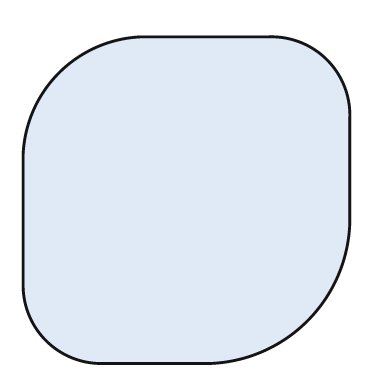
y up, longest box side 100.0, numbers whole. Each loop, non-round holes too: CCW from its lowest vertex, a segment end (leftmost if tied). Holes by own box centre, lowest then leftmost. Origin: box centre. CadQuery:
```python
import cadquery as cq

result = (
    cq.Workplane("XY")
    .moveTo(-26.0, -50.0)
    .lineTo(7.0, -50.0)
    .threePointArc((37.0, -37.0), (50.0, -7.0))
    .lineTo(50.0, 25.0)
    .threePointArc((43.0, 43.0), (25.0, 50.0))
    .lineTo(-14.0, 50.0)
    .threePointArc((-39.0, 39.0), (-50.0, 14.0))
    .lineTo(-50.0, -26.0)
    .threePointArc((-43.0, -43.0), (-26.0, -50.0))
    .close()
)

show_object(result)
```